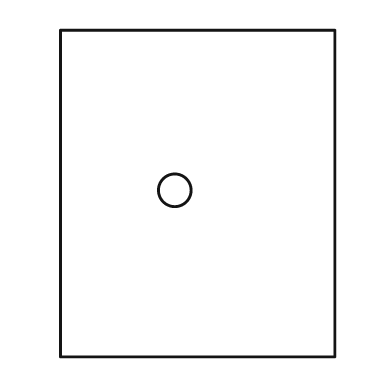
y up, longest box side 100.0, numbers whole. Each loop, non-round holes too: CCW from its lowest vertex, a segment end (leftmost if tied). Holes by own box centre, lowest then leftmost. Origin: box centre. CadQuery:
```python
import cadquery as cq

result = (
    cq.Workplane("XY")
    .moveTo(-42.0, -50.0)
    .lineTo(42.0, -50.0)
    .lineTo(42.0, 50.0)
    .lineTo(-42.0, 50.0)
    .close()
    .moveTo(-7.0, 1.0)
    .circle(5.0)
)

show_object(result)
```